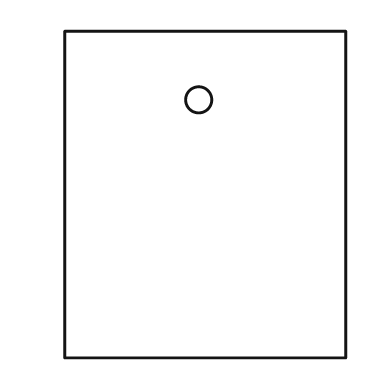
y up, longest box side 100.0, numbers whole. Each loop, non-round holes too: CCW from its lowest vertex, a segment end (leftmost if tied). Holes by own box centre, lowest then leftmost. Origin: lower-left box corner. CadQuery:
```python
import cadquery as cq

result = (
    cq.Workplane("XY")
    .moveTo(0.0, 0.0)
    .lineTo(86.0, 0.0)
    .lineTo(86.0, 100.0)
    .lineTo(0.0, 100.0)
    .close()
    .moveTo(41.0, 79.0)
    .circle(4.0)
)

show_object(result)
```